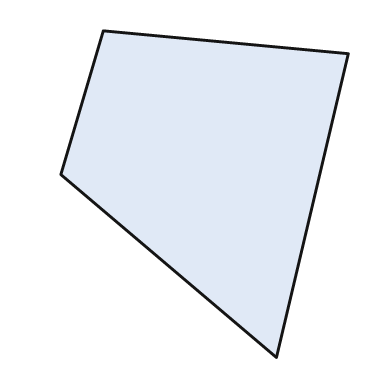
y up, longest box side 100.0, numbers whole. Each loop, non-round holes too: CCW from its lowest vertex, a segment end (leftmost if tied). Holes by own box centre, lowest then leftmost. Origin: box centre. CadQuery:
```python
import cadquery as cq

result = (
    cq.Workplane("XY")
    .moveTo(22.0, -50.0)
    .lineTo(44.0, 43.0)
    .lineTo(-31.0, 50.0)
    .lineTo(-44.0, 6.0)
    .close()
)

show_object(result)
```